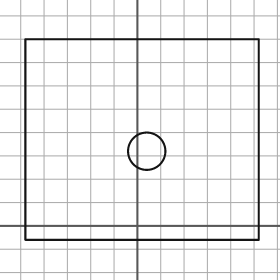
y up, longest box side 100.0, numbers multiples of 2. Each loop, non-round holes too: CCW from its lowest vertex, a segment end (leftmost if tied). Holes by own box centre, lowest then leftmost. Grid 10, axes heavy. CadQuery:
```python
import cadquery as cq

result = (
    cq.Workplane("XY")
    .moveTo(-48.0, -6.0)
    .lineTo(52.0, -6.0)
    .lineTo(52.0, 80.0)
    .lineTo(-48.0, 80.0)
    .close()
    .moveTo(4.0, 32.0)
    .circle(8.0)
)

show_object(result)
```